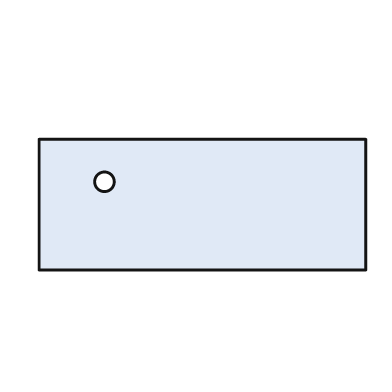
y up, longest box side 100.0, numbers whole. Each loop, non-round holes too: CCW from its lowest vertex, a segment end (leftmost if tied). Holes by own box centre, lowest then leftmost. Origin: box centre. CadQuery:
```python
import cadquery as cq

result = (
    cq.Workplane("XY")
    .moveTo(-50.0, -20.0)
    .lineTo(50.0, -20.0)
    .lineTo(50.0, 20.0)
    .lineTo(-50.0, 20.0)
    .close()
    .moveTo(-30.0, 7.0)
    .circle(3.0)
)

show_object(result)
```